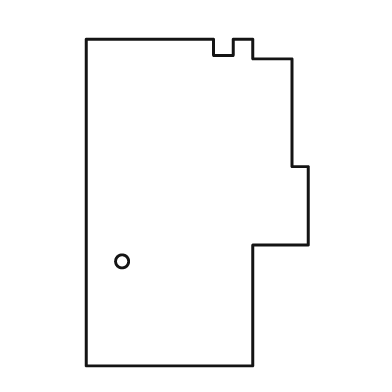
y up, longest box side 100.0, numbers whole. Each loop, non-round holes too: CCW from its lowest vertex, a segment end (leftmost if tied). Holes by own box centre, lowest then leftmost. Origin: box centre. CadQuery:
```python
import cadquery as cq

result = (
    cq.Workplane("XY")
    .moveTo(-34.0, -50.0)
    .lineTo(17.0, -50.0)
    .lineTo(17.0, -13.0)
    .lineTo(34.0, -13.0)
    .lineTo(34.0, 11.0)
    .lineTo(29.0, 11.0)
    .lineTo(29.0, 44.0)
    .lineTo(17.0, 44.0)
    .lineTo(17.0, 50.0)
    .lineTo(11.0, 50.0)
    .lineTo(11.0, 45.0)
    .lineTo(5.0, 45.0)
    .lineTo(5.0, 50.0)
    .lineTo(-34.0, 50.0)
    .close()
    .moveTo(-23.0, -18.0)
    .circle(2.0)
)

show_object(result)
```